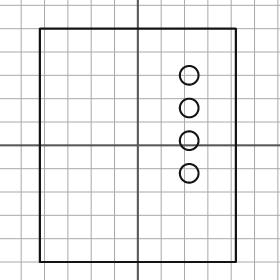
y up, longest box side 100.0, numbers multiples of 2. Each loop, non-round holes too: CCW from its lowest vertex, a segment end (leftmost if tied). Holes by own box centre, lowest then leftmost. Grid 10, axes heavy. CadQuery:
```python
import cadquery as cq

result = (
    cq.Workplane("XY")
    .moveTo(-42.0, -50.0)
    .lineTo(42.0, -50.0)
    .lineTo(42.0, 50.0)
    .lineTo(-42.0, 50.0)
    .close()
    .moveTo(22.0, -12.0)
    .circle(4.0)
    .moveTo(22.0, 2.0)
    .circle(4.0)
    .moveTo(22.0, 16.0)
    .circle(4.0)
    .moveTo(22.0, 30.0)
    .circle(4.0)
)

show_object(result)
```